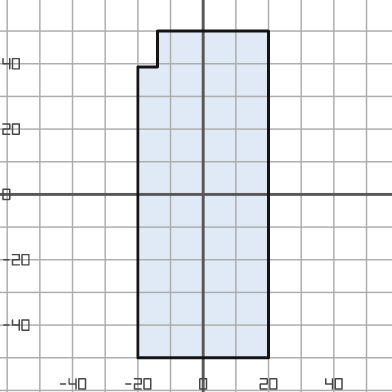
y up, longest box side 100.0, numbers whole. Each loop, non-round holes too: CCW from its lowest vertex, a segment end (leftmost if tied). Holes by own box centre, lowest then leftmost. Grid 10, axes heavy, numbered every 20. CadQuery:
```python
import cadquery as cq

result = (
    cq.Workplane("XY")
    .moveTo(-20.0, -50.0)
    .lineTo(20.0, -50.0)
    .lineTo(20.0, 50.0)
    .lineTo(-14.0, 50.0)
    .lineTo(-14.0, 39.0)
    .lineTo(-20.0, 39.0)
    .close()
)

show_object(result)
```